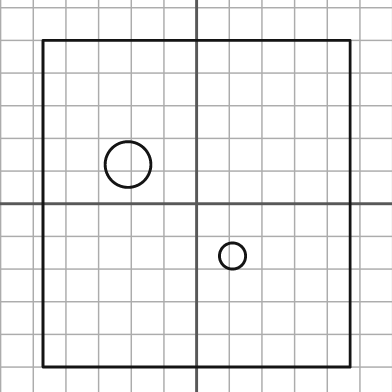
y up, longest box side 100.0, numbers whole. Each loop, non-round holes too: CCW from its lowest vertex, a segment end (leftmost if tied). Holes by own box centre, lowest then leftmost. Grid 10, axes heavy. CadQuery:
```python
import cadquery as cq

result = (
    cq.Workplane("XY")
    .moveTo(-47.0, -50.0)
    .lineTo(47.0, -50.0)
    .lineTo(47.0, 50.0)
    .lineTo(-47.0, 50.0)
    .close()
    .moveTo(11.0, -16.0)
    .circle(4.0)
    .moveTo(-21.0, 12.0)
    .circle(7.0)
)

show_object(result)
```